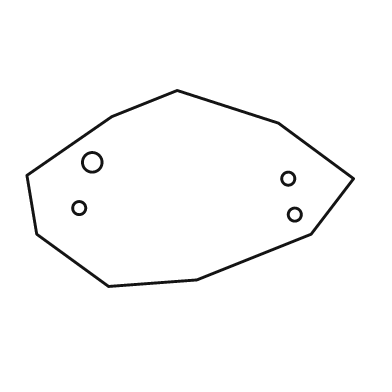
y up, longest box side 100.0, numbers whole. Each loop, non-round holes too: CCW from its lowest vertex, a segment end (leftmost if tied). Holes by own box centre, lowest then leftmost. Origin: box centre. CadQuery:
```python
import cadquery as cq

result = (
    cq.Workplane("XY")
    .moveTo(-25.0, -30.0)
    .lineTo(2.0, -28.0)
    .lineTo(37.0, -14.0)
    .lineTo(50.0, 3.0)
    .lineTo(27.0, 20.0)
    .lineTo(-4.0, 30.0)
    .lineTo(-24.0, 22.0)
    .lineTo(-50.0, 4.0)
    .lineTo(-47.0, -14.0)
    .close()
    .moveTo(32.0, -8.0)
    .circle(2.0)
    .moveTo(-34.0, -6.0)
    .circle(2.0)
    .moveTo(30.0, 3.0)
    .circle(2.0)
    .moveTo(-30.0, 8.0)
    .circle(3.0)
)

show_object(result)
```